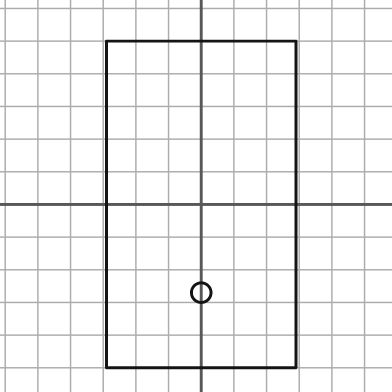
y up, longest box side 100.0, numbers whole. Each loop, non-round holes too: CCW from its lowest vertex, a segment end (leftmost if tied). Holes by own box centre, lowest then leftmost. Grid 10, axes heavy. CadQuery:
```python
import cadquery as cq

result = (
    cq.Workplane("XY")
    .moveTo(-29.0, -50.0)
    .lineTo(29.0, -50.0)
    .lineTo(29.0, 50.0)
    .lineTo(-29.0, 50.0)
    .close()
    .moveTo(0.0, -27.0)
    .circle(3.0)
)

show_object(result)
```